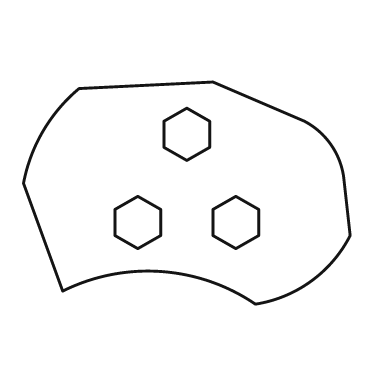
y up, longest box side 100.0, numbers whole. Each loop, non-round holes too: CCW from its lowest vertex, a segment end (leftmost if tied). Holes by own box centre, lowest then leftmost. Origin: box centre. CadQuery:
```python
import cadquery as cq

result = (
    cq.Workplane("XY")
    .moveTo(21.0, -34.0)
    .threePointArc((38.0, -27.0), (50.0, -13.0))
    .lineTo(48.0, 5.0)
    .threePointArc((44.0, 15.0), (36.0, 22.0))
    .lineTo(8.0, 34.0)
    .lineTo(-33.0, 32.0)
    .threePointArc((-44.0, 19.0), (-50.0, 3.0))
    .lineTo(-38.0, -30.0)
    .threePointArc((-8.0, -24.0), (21.0, -34.0))
    .close()
    .moveTo(-15.0, -17.0)
    .lineTo(-8.0, -13.0)
    .lineTo(-8.0, -5.0)
    .lineTo(-15.0, -1.0)
    .lineTo(-22.0, -5.0)
    .lineTo(-22.0, -13.0)
    .close()
    .moveTo(15.0, -17.0)
    .lineTo(22.0, -13.0)
    .lineTo(22.0, -5.0)
    .lineTo(15.0, -1.0)
    .lineTo(8.0, -5.0)
    .lineTo(8.0, -13.0)
    .close()
    .moveTo(0.0, 10.0)
    .lineTo(7.0, 14.0)
    .lineTo(7.0, 22.0)
    .lineTo(0.0, 26.0)
    .lineTo(-7.0, 22.0)
    .lineTo(-7.0, 14.0)
    .close()
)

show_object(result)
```